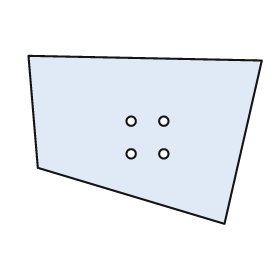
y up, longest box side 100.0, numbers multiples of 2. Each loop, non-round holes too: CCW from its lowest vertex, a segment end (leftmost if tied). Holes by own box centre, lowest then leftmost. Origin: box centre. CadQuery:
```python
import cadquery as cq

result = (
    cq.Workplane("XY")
    .moveTo(34.0, -36.0)
    .lineTo(50.0, 34.0)
    .lineTo(-50.0, 36.0)
    .lineTo(-46.0, -12.0)
    .close()
    .moveTo(-6.0, -6.0)
    .circle(2.0)
    .moveTo(8.0, -6.0)
    .circle(2.0)
    .moveTo(-6.0, 8.0)
    .circle(2.0)
    .moveTo(8.0, 8.0)
    .circle(2.0)
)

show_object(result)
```